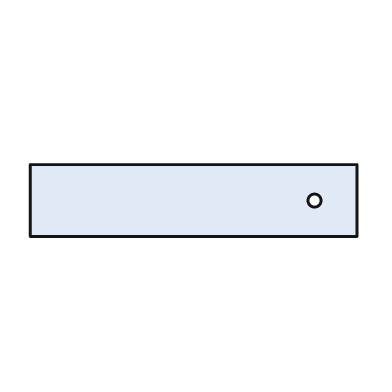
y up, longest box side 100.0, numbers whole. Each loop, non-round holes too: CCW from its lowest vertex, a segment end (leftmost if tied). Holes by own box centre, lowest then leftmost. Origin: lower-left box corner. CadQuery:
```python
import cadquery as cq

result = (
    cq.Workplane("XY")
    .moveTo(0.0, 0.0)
    .lineTo(100.0, 0.0)
    .lineTo(100.0, 22.0)
    .lineTo(0.0, 22.0)
    .close()
    .moveTo(87.0, 11.0)
    .circle(2.0)
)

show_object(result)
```